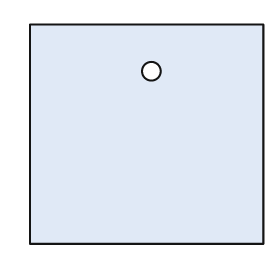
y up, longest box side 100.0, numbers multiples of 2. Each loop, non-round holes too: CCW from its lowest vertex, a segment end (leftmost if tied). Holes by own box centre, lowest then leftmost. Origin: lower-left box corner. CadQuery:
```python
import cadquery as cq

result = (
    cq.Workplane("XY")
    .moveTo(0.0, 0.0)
    .lineTo(100.0, 0.0)
    .lineTo(100.0, 94.0)
    .lineTo(0.0, 94.0)
    .close()
    .moveTo(52.0, 74.0)
    .circle(4.0)
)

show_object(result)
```